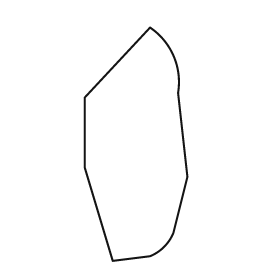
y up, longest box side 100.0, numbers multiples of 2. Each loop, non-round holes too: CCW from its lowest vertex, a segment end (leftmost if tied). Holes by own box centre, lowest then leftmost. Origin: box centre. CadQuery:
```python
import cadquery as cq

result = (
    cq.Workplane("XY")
    .moveTo(-10.0, -50.0)
    .lineTo(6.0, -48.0)
    .threePointArc((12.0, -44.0), (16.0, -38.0))
    .lineTo(22.0, -14.0)
    .lineTo(18.0, 22.0)
    .threePointArc((16.0, 38.0), (6.0, 50.0))
    .lineTo(-22.0, 20.0)
    .lineTo(-22.0, -10.0)
    .close()
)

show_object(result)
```